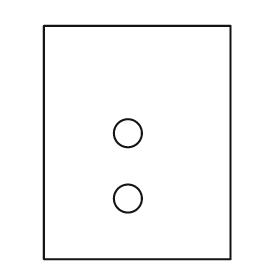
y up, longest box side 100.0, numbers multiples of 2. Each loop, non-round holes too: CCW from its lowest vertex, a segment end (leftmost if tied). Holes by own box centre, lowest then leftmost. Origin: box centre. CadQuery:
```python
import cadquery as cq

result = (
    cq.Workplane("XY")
    .moveTo(-40.0, -50.0)
    .lineTo(40.0, -50.0)
    .lineTo(40.0, 50.0)
    .lineTo(-40.0, 50.0)
    .close()
    .moveTo(-4.0, -24.0)
    .circle(6.0)
    .moveTo(-4.0, 4.0)
    .circle(6.0)
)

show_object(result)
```